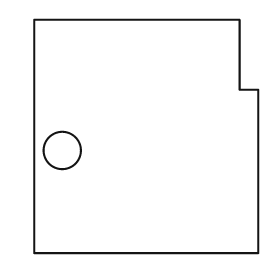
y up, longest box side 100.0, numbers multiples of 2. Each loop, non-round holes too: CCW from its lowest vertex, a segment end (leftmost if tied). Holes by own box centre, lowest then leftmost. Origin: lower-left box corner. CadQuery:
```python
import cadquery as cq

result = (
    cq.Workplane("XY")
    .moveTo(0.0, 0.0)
    .lineTo(96.0, 0.0)
    .lineTo(96.0, 70.0)
    .lineTo(88.0, 70.0)
    .lineTo(88.0, 100.0)
    .lineTo(0.0, 100.0)
    .close()
    .moveTo(12.0, 44.0)
    .circle(8.0)
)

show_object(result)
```